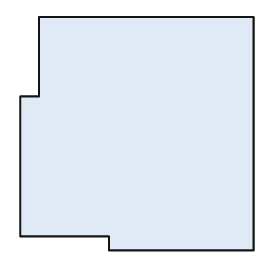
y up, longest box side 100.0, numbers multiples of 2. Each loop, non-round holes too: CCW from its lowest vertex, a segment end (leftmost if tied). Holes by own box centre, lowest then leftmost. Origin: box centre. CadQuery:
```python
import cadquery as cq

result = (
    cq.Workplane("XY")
    .moveTo(-12.0, -50.0)
    .lineTo(50.0, -50.0)
    .lineTo(50.0, 50.0)
    .lineTo(-42.0, 50.0)
    .lineTo(-42.0, 16.0)
    .lineTo(-50.0, 16.0)
    .lineTo(-50.0, -44.0)
    .lineTo(-12.0, -44.0)
    .close()
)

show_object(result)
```